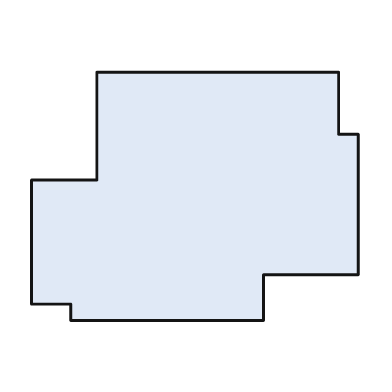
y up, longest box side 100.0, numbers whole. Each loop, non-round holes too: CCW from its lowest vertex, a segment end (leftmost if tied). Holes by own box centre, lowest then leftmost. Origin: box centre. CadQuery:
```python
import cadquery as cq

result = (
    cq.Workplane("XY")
    .moveTo(-38.0, -38.0)
    .lineTo(21.0, -38.0)
    .lineTo(21.0, -24.0)
    .lineTo(50.0, -24.0)
    .lineTo(50.0, 19.0)
    .lineTo(44.0, 19.0)
    .lineTo(44.0, 38.0)
    .lineTo(-30.0, 38.0)
    .lineTo(-30.0, 5.0)
    .lineTo(-50.0, 5.0)
    .lineTo(-50.0, -33.0)
    .lineTo(-38.0, -33.0)
    .close()
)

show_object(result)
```